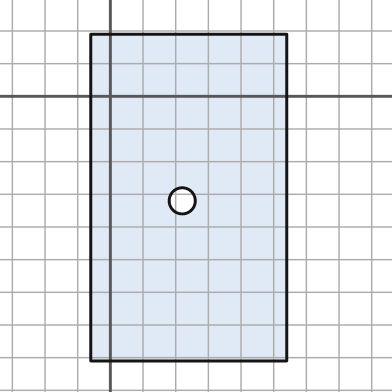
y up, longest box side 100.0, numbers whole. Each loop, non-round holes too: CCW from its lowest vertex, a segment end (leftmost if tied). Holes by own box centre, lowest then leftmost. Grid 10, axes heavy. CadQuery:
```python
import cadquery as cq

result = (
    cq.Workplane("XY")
    .moveTo(-6.0, -81.0)
    .lineTo(54.0, -81.0)
    .lineTo(54.0, 19.0)
    .lineTo(-6.0, 19.0)
    .close()
    .moveTo(22.0, -32.0)
    .circle(4.0)
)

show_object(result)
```